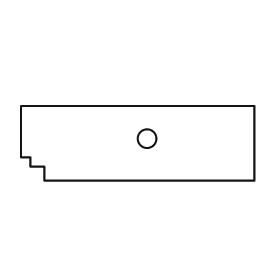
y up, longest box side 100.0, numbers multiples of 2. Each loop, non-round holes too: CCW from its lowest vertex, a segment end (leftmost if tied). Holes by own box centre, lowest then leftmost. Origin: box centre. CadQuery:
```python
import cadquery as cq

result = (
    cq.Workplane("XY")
    .moveTo(-40.0, -16.0)
    .lineTo(50.0, -16.0)
    .lineTo(50.0, 16.0)
    .lineTo(-50.0, 16.0)
    .lineTo(-50.0, -6.0)
    .lineTo(-46.0, -6.0)
    .lineTo(-46.0, -10.0)
    .lineTo(-40.0, -10.0)
    .close()
    .moveTo(4.0, 2.0)
    .circle(4.0)
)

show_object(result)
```